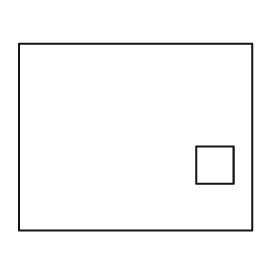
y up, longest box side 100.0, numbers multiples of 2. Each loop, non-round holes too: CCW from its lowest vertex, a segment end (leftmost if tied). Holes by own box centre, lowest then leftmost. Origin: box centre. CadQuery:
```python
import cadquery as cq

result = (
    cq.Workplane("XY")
    .moveTo(-50.0, -40.0)
    .lineTo(50.0, -40.0)
    .lineTo(50.0, 40.0)
    .lineTo(-50.0, 40.0)
    .close()
    .moveTo(26.0, -20.0)
    .lineTo(42.0, -20.0)
    .lineTo(42.0, -4.0)
    .lineTo(26.0, -4.0)
    .close()
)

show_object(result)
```